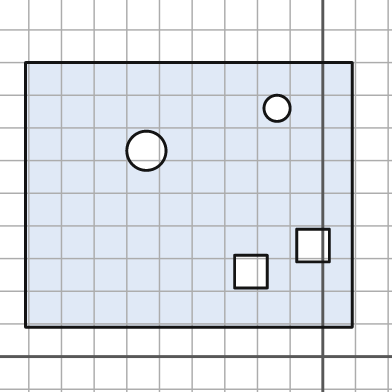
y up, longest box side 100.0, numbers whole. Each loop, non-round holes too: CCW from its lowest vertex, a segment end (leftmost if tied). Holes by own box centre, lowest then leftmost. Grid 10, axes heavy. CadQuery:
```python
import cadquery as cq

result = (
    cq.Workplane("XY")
    .moveTo(-91.0, 9.0)
    .lineTo(9.0, 9.0)
    .lineTo(9.0, 90.0)
    .lineTo(-91.0, 90.0)
    .close()
    .moveTo(-27.0, 21.0)
    .lineTo(-17.0, 21.0)
    .lineTo(-17.0, 31.0)
    .lineTo(-27.0, 31.0)
    .close()
    .moveTo(-8.0, 29.0)
    .lineTo(2.0, 29.0)
    .lineTo(2.0, 39.0)
    .lineTo(-8.0, 39.0)
    .close()
    .moveTo(-54.0, 63.0)
    .circle(6.0)
    .moveTo(-14.0, 76.0)
    .circle(4.0)
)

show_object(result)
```